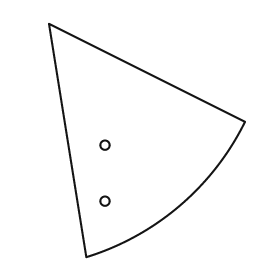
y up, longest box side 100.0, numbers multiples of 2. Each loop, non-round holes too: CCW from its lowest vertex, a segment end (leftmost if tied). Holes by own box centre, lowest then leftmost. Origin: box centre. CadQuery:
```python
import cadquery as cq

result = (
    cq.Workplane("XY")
    .moveTo(-26.0, -50.0)
    .threePointArc((14.0, -28.0), (42.0, 8.0))
    .lineTo(-42.0, 50.0)
    .close()
    .moveTo(-18.0, -26.0)
    .circle(2.0)
    .moveTo(-18.0, -2.0)
    .circle(2.0)
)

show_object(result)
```